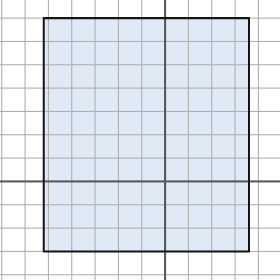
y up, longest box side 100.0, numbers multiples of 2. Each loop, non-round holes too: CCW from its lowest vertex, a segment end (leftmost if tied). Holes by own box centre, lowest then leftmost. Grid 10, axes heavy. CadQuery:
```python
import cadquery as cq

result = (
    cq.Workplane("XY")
    .moveTo(-52.0, -30.0)
    .lineTo(36.0, -30.0)
    .lineTo(36.0, 70.0)
    .lineTo(-52.0, 70.0)
    .close()
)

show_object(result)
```